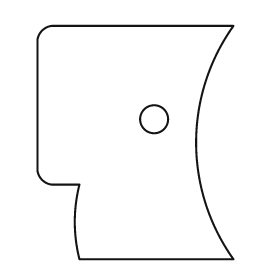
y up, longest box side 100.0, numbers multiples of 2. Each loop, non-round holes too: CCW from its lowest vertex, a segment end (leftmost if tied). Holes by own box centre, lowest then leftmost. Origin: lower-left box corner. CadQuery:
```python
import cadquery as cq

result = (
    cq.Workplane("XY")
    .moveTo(18.0, 0.0)
    .lineTo(84.0, 0.0)
    .threePointArc((68.0, 50.0), (84.0, 100.0))
    .lineTo(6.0, 100.0)
    .threePointArc((2.0, 98.0), (0.0, 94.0))
    .lineTo(0.0, 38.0)
    .threePointArc((2.0, 34.0), (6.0, 32.0))
    .lineTo(18.0, 32.0)
    .threePointArc((16.0, 16.0), (18.0, 0.0))
    .close()
    .moveTo(50.0, 60.0)
    .circle(6.0)
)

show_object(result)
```